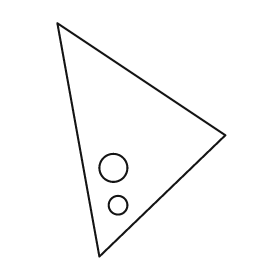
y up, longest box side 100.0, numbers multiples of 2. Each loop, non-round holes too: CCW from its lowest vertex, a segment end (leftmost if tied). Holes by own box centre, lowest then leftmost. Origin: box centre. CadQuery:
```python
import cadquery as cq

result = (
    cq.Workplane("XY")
    .moveTo(-18.0, -50.0)
    .lineTo(36.0, 2.0)
    .lineTo(-36.0, 50.0)
    .close()
    .moveTo(-10.0, -28.0)
    .circle(4.0)
    .moveTo(-12.0, -12.0)
    .circle(6.0)
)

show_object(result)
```